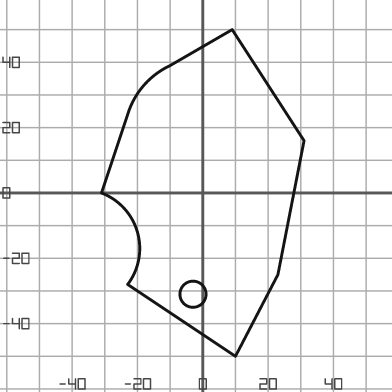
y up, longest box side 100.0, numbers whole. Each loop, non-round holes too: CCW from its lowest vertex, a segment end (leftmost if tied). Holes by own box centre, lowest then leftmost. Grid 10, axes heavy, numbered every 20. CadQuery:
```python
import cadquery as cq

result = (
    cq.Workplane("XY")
    .moveTo(10.0, -50.0)
    .lineTo(23.0, -25.0)
    .lineTo(31.0, 16.0)
    .lineTo(9.0, 50.0)
    .lineTo(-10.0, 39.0)
    .threePointArc((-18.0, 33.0), (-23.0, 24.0))
    .lineTo(-31.0, 0.0)
    .threePointArc((-20.0, -12.0), (-23.0, -28.0))
    .close()
    .moveTo(-3.0, -31.0)
    .circle(4.0)
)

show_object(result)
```